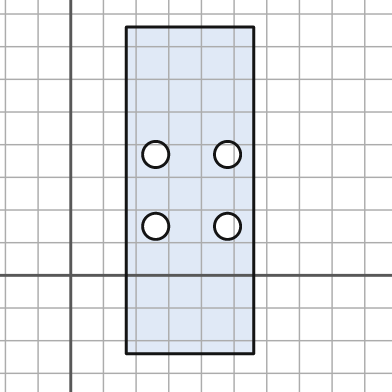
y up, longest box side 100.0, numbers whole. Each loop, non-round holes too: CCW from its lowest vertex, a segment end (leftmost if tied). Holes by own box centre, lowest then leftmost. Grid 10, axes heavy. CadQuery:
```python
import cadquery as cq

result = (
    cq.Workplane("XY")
    .moveTo(17.0, -24.0)
    .lineTo(56.0, -24.0)
    .lineTo(56.0, 76.0)
    .lineTo(17.0, 76.0)
    .close()
    .moveTo(26.0, 15.0)
    .circle(4.0)
    .moveTo(48.0, 15.0)
    .circle(4.0)
    .moveTo(26.0, 37.0)
    .circle(4.0)
    .moveTo(48.0, 37.0)
    .circle(4.0)
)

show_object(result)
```